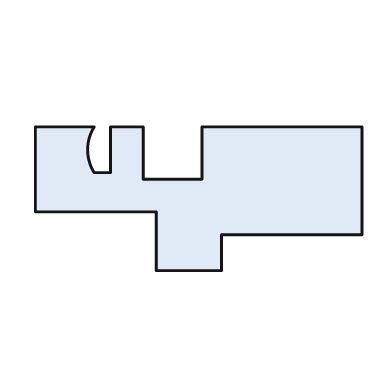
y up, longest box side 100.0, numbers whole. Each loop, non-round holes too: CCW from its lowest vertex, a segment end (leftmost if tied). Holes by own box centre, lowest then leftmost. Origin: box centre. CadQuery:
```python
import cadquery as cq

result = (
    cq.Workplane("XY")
    .moveTo(-13.0, -22.0)
    .lineTo(7.0, -22.0)
    .lineTo(7.0, -11.0)
    .lineTo(50.0, -11.0)
    .lineTo(50.0, 22.0)
    .lineTo(1.0, 22.0)
    .lineTo(1.0, 6.0)
    .lineTo(-17.0, 6.0)
    .lineTo(-17.0, 22.0)
    .lineTo(-27.0, 22.0)
    .lineTo(-27.0, 8.0)
    .lineTo(-32.0, 8.0)
    .threePointArc((-34.0, 15.0), (-32.0, 22.0))
    .lineTo(-50.0, 22.0)
    .lineTo(-50.0, -4.0)
    .lineTo(-13.0, -4.0)
    .close()
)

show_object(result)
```